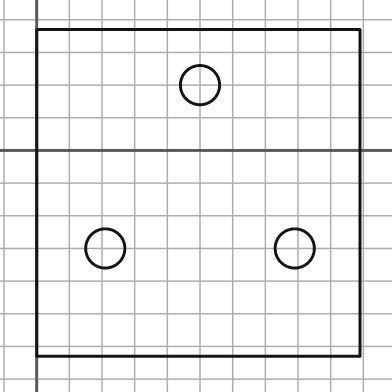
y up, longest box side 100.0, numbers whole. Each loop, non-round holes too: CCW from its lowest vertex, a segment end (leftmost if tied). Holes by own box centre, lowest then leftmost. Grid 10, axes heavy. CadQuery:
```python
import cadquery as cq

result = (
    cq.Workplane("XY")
    .moveTo(0.0, -63.0)
    .lineTo(99.0, -63.0)
    .lineTo(99.0, 37.0)
    .lineTo(0.0, 37.0)
    .close()
    .moveTo(21.0, -30.0)
    .circle(6.0)
    .moveTo(79.0, -30.0)
    .circle(6.0)
    .moveTo(50.0, 20.0)
    .circle(6.0)
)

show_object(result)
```